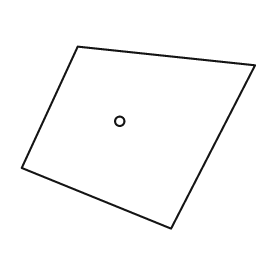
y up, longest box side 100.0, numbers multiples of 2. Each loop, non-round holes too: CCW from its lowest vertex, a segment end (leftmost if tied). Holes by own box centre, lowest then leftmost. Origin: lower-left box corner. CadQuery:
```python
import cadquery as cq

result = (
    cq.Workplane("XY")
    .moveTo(64.0, 0.0)
    .lineTo(100.0, 70.0)
    .lineTo(24.0, 78.0)
    .lineTo(0.0, 26.0)
    .close()
    .moveTo(42.0, 46.0)
    .circle(2.0)
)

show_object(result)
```